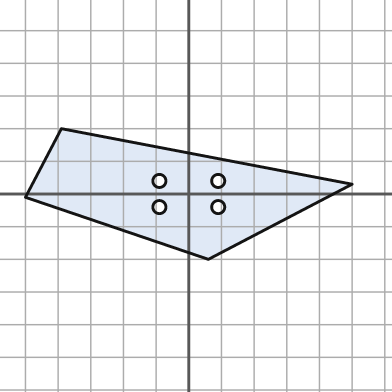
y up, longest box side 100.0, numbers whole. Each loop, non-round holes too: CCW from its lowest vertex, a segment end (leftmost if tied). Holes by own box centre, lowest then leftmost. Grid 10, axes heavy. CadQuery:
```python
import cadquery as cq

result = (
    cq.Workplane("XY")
    .moveTo(6.0, -20.0)
    .lineTo(50.0, 3.0)
    .lineTo(-39.0, 20.0)
    .lineTo(-50.0, -1.0)
    .close()
    .moveTo(-9.0, -4.0)
    .circle(2.0)
    .moveTo(9.0, -4.0)
    .circle(2.0)
    .moveTo(-9.0, 4.0)
    .circle(2.0)
    .moveTo(9.0, 4.0)
    .circle(2.0)
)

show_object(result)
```